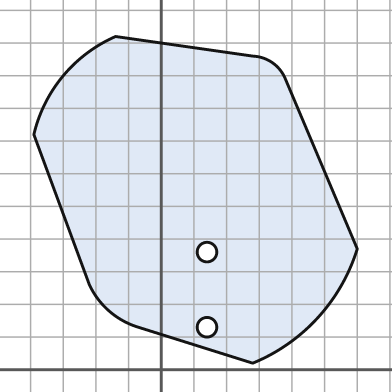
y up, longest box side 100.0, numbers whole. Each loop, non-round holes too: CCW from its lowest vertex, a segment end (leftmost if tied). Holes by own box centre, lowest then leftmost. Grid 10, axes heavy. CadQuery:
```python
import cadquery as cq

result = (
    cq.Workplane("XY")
    .moveTo(28.0, 2.0)
    .threePointArc((48.0, 16.0), (60.0, 37.0))
    .lineTo(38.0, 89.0)
    .threePointArc((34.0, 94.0), (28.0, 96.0))
    .lineTo(-14.0, 102.0)
    .threePointArc((-30.0, 90.0), (-39.0, 72.0))
    .lineTo(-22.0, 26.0)
    .threePointArc((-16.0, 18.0), (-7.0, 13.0))
    .close()
    .moveTo(14.0, 13.0)
    .circle(3.0)
    .moveTo(14.0, 36.0)
    .circle(3.0)
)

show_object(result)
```